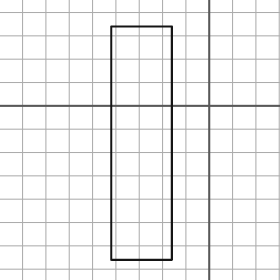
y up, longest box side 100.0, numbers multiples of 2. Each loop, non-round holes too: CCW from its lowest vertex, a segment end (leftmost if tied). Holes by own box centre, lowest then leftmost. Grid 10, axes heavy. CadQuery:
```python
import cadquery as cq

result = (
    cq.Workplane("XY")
    .moveTo(-42.0, -66.0)
    .lineTo(-16.0, -66.0)
    .lineTo(-16.0, 34.0)
    .lineTo(-42.0, 34.0)
    .close()
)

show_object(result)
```